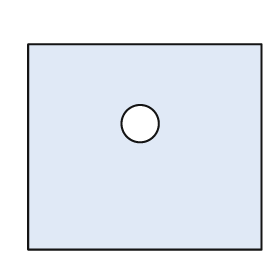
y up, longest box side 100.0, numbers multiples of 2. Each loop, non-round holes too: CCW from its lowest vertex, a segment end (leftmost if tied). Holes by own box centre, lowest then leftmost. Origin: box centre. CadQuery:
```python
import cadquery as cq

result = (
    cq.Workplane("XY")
    .moveTo(-50.0, -44.0)
    .lineTo(50.0, -44.0)
    .lineTo(50.0, 44.0)
    .lineTo(-50.0, 44.0)
    .close()
    .moveTo(-2.0, 10.0)
    .circle(8.0)
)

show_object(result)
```